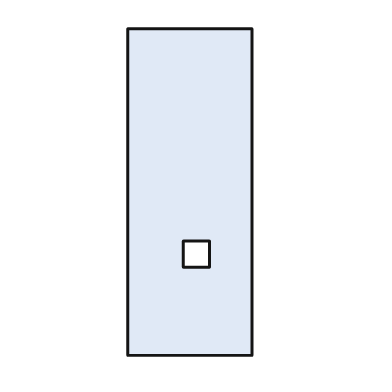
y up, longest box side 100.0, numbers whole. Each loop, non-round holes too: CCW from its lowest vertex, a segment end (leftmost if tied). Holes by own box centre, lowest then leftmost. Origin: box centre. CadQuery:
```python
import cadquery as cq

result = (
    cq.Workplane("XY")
    .moveTo(-19.0, -50.0)
    .lineTo(19.0, -50.0)
    .lineTo(19.0, 50.0)
    .lineTo(-19.0, 50.0)
    .close()
    .moveTo(-2.0, -23.0)
    .lineTo(6.0, -23.0)
    .lineTo(6.0, -15.0)
    .lineTo(-2.0, -15.0)
    .close()
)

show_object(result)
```